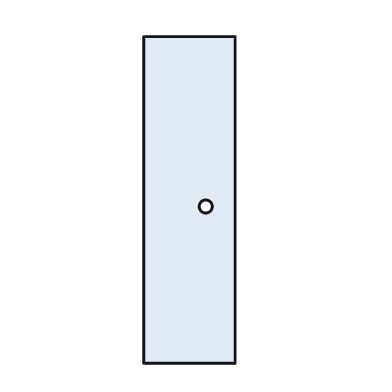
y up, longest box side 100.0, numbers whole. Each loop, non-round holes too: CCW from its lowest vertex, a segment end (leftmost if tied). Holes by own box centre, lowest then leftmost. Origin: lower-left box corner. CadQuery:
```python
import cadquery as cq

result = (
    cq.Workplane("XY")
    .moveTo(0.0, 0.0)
    .lineTo(28.0, 0.0)
    .lineTo(28.0, 100.0)
    .lineTo(0.0, 100.0)
    .close()
    .moveTo(19.0, 48.0)
    .circle(2.0)
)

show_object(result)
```